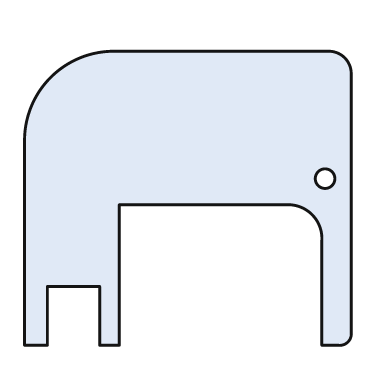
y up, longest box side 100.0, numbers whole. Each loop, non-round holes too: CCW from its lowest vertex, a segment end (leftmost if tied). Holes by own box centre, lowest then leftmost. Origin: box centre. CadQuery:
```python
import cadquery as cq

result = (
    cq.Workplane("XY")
    .moveTo(-50.0, -45.0)
    .lineTo(-43.0, -45.0)
    .lineTo(-43.0, -27.0)
    .lineTo(-27.0, -27.0)
    .lineTo(-27.0, -45.0)
    .lineTo(-21.0, -45.0)
    .lineTo(-21.0, -2.0)
    .lineTo(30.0, -2.0)
    .threePointArc((38.0, -5.0), (41.0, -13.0))
    .lineTo(41.0, -45.0)
    .lineTo(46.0, -45.0)
    .threePointArc((49.0, -44.0), (50.0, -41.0))
    .lineTo(50.0, 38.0)
    .threePointArc((48.0, 43.0), (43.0, 45.0))
    .lineTo(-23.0, 45.0)
    .threePointArc((-42.0, 37.0), (-50.0, 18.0))
    .close()
    .moveTo(42.0, 6.0)
    .circle(3.0)
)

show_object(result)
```